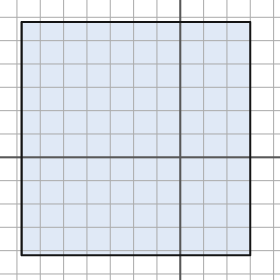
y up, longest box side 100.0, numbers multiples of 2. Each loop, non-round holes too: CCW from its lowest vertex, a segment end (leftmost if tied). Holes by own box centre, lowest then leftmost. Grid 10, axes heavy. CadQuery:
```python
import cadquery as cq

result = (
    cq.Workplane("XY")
    .moveTo(-68.0, -42.0)
    .lineTo(30.0, -42.0)
    .lineTo(30.0, 58.0)
    .lineTo(-68.0, 58.0)
    .close()
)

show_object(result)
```